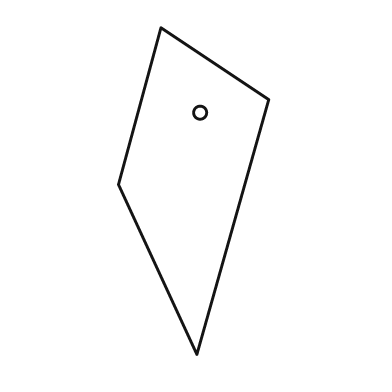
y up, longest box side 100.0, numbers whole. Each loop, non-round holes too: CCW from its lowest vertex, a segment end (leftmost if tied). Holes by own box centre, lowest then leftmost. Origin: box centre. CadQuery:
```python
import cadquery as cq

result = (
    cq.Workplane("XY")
    .moveTo(1.0, -50.0)
    .lineTo(23.0, 28.0)
    .lineTo(-10.0, 50.0)
    .lineTo(-23.0, 2.0)
    .close()
    .moveTo(2.0, 24.0)
    .circle(2.0)
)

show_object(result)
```